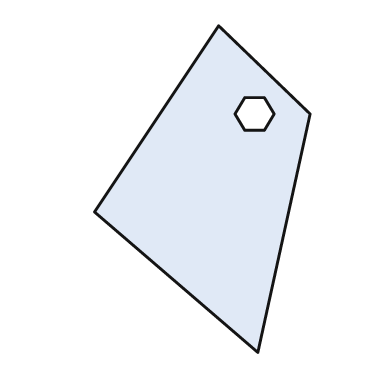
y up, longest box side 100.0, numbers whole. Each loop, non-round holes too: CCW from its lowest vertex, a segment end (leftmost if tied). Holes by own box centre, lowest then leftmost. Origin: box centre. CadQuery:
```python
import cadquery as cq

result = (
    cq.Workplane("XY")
    .moveTo(17.0, -50.0)
    .lineTo(33.0, 23.0)
    .lineTo(5.0, 50.0)
    .lineTo(-33.0, -7.0)
    .close()
    .moveTo(13.0, 18.0)
    .lineTo(19.0, 18.0)
    .lineTo(22.0, 23.0)
    .lineTo(19.0, 28.0)
    .lineTo(13.0, 28.0)
    .lineTo(10.0, 23.0)
    .close()
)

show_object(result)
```